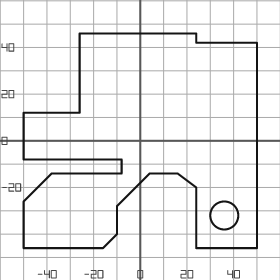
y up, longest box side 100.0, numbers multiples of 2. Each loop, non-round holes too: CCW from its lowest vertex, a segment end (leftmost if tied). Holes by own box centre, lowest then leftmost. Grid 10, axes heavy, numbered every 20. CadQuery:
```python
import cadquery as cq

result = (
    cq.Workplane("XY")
    .moveTo(-50.0, -46.0)
    .lineTo(-16.0, -46.0)
    .lineTo(-10.0, -40.0)
    .lineTo(-10.0, -28.0)
    .lineTo(4.0, -14.0)
    .lineTo(16.0, -14.0)
    .lineTo(24.0, -20.0)
    .lineTo(24.0, -46.0)
    .lineTo(50.0, -46.0)
    .lineTo(50.0, 42.0)
    .lineTo(24.0, 42.0)
    .lineTo(24.0, 46.0)
    .lineTo(-26.0, 46.0)
    .lineTo(-26.0, 12.0)
    .lineTo(-50.0, 12.0)
    .lineTo(-50.0, -8.0)
    .lineTo(-8.0, -8.0)
    .lineTo(-8.0, -14.0)
    .lineTo(-38.0, -14.0)
    .lineTo(-50.0, -26.0)
    .close()
    .moveTo(36.0, -32.0)
    .circle(6.0)
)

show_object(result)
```